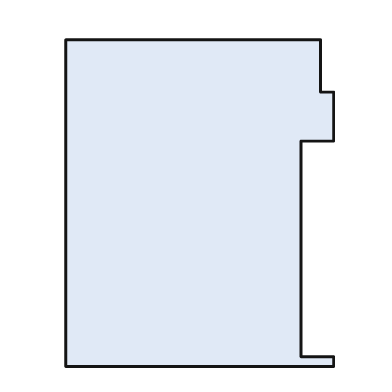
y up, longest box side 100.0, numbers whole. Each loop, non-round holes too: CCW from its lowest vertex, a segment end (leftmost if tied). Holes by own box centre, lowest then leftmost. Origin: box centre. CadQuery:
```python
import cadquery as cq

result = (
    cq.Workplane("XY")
    .moveTo(-41.0, -50.0)
    .lineTo(41.0, -50.0)
    .lineTo(41.0, -47.0)
    .lineTo(31.0, -47.0)
    .lineTo(31.0, 19.0)
    .lineTo(41.0, 19.0)
    .lineTo(41.0, 34.0)
    .lineTo(37.0, 34.0)
    .lineTo(37.0, 50.0)
    .lineTo(-41.0, 50.0)
    .close()
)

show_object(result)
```